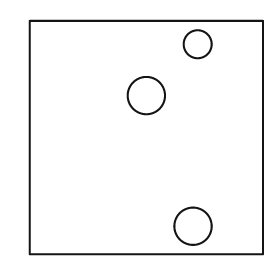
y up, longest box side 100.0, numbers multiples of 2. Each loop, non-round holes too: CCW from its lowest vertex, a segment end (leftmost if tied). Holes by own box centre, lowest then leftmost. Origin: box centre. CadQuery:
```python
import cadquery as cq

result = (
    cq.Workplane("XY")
    .moveTo(-50.0, -50.0)
    .lineTo(50.0, -50.0)
    .lineTo(50.0, 50.0)
    .lineTo(-50.0, 50.0)
    .close()
    .moveTo(20.0, -38.0)
    .circle(8.0)
    .moveTo(0.0, 18.0)
    .circle(8.0)
    .moveTo(22.0, 40.0)
    .circle(6.0)
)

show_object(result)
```